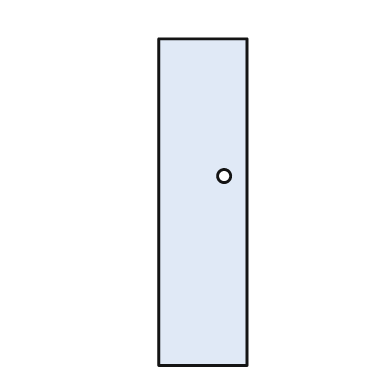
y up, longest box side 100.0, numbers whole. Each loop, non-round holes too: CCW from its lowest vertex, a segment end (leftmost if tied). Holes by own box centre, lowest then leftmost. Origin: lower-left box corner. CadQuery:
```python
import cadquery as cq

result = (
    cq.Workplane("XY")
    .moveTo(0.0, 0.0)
    .lineTo(27.0, 0.0)
    .lineTo(27.0, 100.0)
    .lineTo(0.0, 100.0)
    .close()
    .moveTo(20.0, 58.0)
    .circle(2.0)
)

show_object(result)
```